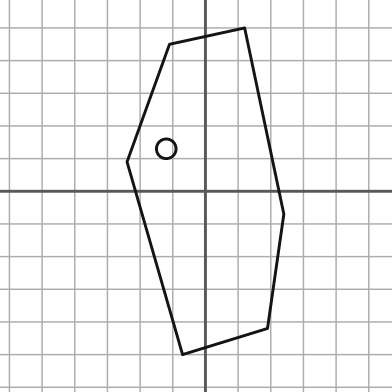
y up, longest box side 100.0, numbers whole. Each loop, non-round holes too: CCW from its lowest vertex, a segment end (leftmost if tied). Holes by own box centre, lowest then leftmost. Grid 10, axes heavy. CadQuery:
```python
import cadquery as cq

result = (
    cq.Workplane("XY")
    .moveTo(-7.0, -50.0)
    .lineTo(19.0, -42.0)
    .lineTo(24.0, -7.0)
    .lineTo(12.0, 50.0)
    .lineTo(-11.0, 45.0)
    .lineTo(-24.0, 9.0)
    .close()
    .moveTo(-12.0, 13.0)
    .circle(3.0)
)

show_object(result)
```